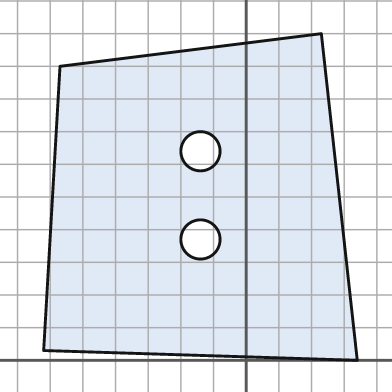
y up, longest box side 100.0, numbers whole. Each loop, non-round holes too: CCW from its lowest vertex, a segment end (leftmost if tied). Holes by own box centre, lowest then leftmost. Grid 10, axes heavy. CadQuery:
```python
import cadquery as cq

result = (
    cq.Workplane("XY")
    .moveTo(34.0, 0.0)
    .lineTo(23.0, 100.0)
    .lineTo(-57.0, 90.0)
    .lineTo(-62.0, 3.0)
    .close()
    .moveTo(-14.0, 37.0)
    .circle(6.0)
    .moveTo(-14.0, 64.0)
    .circle(6.0)
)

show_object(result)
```